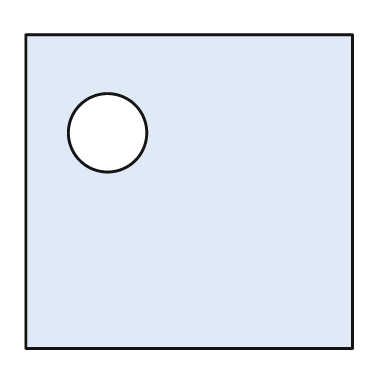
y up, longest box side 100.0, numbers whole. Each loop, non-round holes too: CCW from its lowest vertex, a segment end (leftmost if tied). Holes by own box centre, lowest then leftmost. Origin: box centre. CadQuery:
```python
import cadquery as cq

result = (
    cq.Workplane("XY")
    .moveTo(-50.0, -48.0)
    .lineTo(50.0, -48.0)
    .lineTo(50.0, 48.0)
    .lineTo(-50.0, 48.0)
    .close()
    .moveTo(-25.0, 18.0)
    .circle(12.0)
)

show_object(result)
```